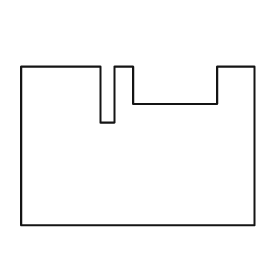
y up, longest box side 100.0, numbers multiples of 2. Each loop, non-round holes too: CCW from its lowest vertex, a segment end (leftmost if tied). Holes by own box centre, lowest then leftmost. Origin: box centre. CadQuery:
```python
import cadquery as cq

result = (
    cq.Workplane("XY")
    .moveTo(-50.0, -34.0)
    .lineTo(50.0, -34.0)
    .lineTo(50.0, 34.0)
    .lineTo(34.0, 34.0)
    .lineTo(34.0, 18.0)
    .lineTo(-2.0, 18.0)
    .lineTo(-2.0, 34.0)
    .lineTo(-10.0, 34.0)
    .lineTo(-10.0, 10.0)
    .lineTo(-16.0, 10.0)
    .lineTo(-16.0, 34.0)
    .lineTo(-50.0, 34.0)
    .close()
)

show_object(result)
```